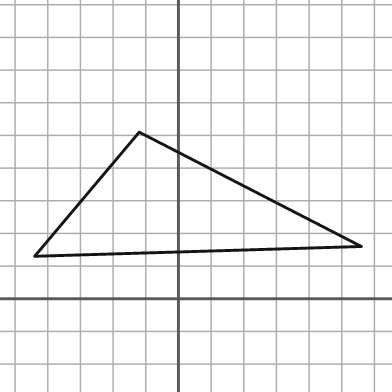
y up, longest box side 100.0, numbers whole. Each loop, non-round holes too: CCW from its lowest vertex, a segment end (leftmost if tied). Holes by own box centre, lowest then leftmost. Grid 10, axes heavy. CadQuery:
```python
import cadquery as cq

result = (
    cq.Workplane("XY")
    .moveTo(-44.0, 13.0)
    .lineTo(56.0, 16.0)
    .lineTo(-12.0, 51.0)
    .close()
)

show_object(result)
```